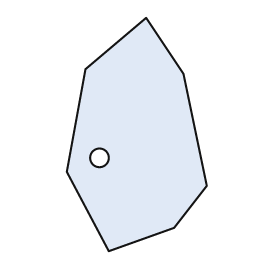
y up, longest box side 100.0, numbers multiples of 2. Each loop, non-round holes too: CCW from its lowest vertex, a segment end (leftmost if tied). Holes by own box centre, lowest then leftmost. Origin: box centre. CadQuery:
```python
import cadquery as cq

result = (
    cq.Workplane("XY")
    .moveTo(-12.0, -50.0)
    .lineTo(16.0, -40.0)
    .lineTo(30.0, -22.0)
    .lineTo(20.0, 26.0)
    .lineTo(4.0, 50.0)
    .lineTo(-22.0, 28.0)
    .lineTo(-30.0, -16.0)
    .close()
    .moveTo(-16.0, -10.0)
    .circle(4.0)
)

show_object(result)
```